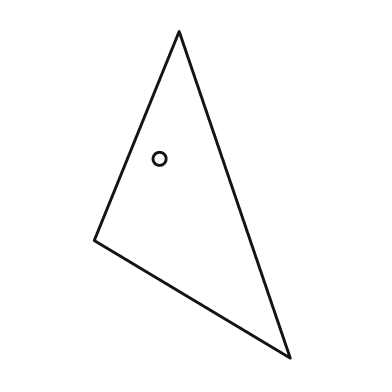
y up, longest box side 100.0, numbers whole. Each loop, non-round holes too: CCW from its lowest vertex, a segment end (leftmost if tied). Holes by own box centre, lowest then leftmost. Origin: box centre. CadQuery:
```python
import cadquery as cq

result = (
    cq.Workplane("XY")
    .moveTo(30.0, -50.0)
    .lineTo(-4.0, 50.0)
    .lineTo(-30.0, -14.0)
    .close()
    .moveTo(-10.0, 11.0)
    .circle(2.0)
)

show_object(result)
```